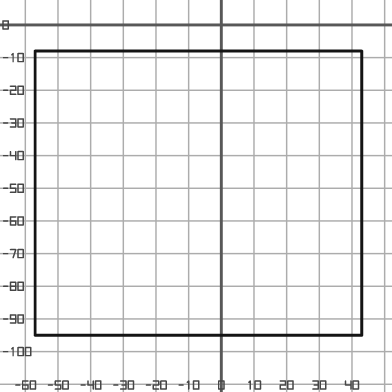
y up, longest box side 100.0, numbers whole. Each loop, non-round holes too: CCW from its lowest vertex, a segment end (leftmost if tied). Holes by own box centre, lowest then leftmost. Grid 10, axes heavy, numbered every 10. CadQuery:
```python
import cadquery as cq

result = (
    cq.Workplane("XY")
    .moveTo(-57.0, -95.0)
    .lineTo(43.0, -95.0)
    .lineTo(43.0, -8.0)
    .lineTo(-57.0, -8.0)
    .close()
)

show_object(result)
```